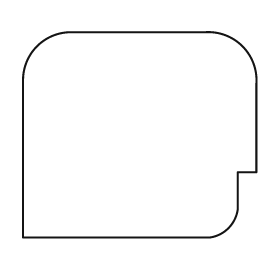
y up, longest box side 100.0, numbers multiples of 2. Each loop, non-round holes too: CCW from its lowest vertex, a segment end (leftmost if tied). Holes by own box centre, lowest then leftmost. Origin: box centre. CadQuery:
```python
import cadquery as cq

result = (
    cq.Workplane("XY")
    .moveTo(-50.0, -44.0)
    .lineTo(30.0, -44.0)
    .threePointArc((38.0, -40.0), (42.0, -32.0))
    .lineTo(42.0, -16.0)
    .lineTo(50.0, -16.0)
    .lineTo(50.0, 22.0)
    .threePointArc((44.0, 38.0), (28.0, 44.0))
    .lineTo(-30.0, 44.0)
    .threePointArc((-44.0, 38.0), (-50.0, 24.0))
    .close()
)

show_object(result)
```